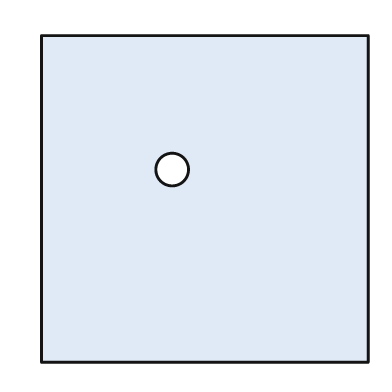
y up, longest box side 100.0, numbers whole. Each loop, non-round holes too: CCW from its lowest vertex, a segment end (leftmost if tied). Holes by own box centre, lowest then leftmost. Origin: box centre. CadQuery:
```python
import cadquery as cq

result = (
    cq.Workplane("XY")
    .moveTo(-50.0, -50.0)
    .lineTo(50.0, -50.0)
    .lineTo(50.0, 50.0)
    .lineTo(-50.0, 50.0)
    .close()
    .moveTo(-10.0, 9.0)
    .circle(5.0)
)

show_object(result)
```